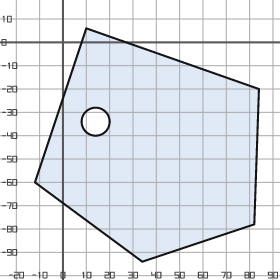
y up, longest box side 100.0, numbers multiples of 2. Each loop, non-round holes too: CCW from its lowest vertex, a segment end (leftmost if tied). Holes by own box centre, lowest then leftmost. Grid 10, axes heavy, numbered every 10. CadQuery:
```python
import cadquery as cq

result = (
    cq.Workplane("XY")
    .moveTo(34.0, -94.0)
    .lineTo(82.0, -78.0)
    .lineTo(84.0, -20.0)
    .lineTo(10.0, 6.0)
    .lineTo(-12.0, -60.0)
    .close()
    .moveTo(14.0, -34.0)
    .circle(6.0)
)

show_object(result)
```